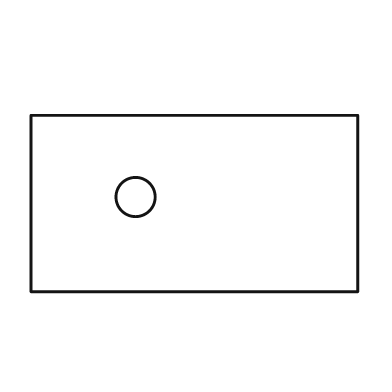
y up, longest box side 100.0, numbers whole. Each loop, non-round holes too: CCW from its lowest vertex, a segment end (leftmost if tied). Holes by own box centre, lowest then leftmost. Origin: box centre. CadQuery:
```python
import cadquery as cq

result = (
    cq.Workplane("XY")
    .moveTo(-50.0, -27.0)
    .lineTo(50.0, -27.0)
    .lineTo(50.0, 27.0)
    .lineTo(-50.0, 27.0)
    .close()
    .moveTo(-18.0, 2.0)
    .circle(6.0)
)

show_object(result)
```